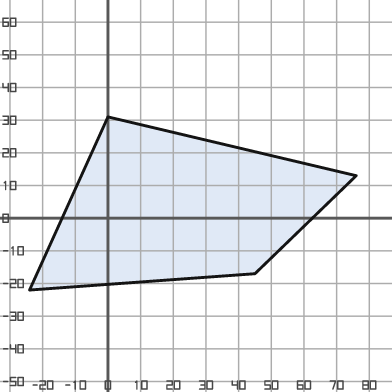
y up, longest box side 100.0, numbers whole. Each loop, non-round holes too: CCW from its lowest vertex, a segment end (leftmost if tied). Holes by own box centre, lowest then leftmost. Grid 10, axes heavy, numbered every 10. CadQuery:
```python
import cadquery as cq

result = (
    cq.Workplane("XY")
    .moveTo(-24.0, -22.0)
    .lineTo(45.0, -17.0)
    .lineTo(76.0, 13.0)
    .lineTo(0.0, 31.0)
    .close()
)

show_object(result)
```